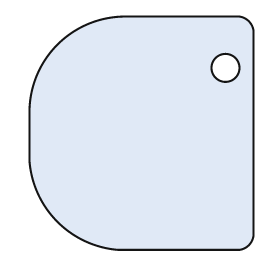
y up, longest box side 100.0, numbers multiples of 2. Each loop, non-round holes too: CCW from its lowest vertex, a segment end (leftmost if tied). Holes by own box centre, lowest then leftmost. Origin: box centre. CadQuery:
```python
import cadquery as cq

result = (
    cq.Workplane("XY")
    .moveTo(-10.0, -50.0)
    .lineTo(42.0, -50.0)
    .threePointArc((46.0, -48.0), (48.0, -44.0))
    .lineTo(48.0, 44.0)
    .threePointArc((46.0, 48.0), (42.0, 50.0))
    .lineTo(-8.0, 50.0)
    .threePointArc((-36.0, 38.0), (-48.0, 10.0))
    .lineTo(-48.0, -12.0)
    .threePointArc((-36.0, -38.0), (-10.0, -50.0))
    .close()
    .moveTo(36.0, 28.0)
    .circle(6.0)
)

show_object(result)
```